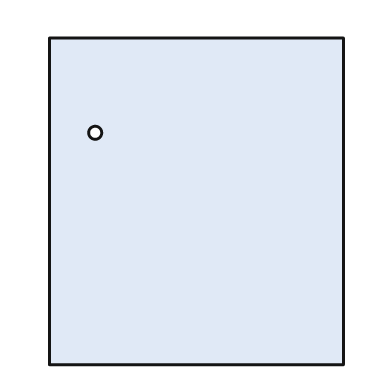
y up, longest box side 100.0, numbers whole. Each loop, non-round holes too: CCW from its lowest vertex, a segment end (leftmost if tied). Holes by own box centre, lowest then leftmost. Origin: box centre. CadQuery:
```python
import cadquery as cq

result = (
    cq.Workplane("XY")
    .moveTo(-45.0, -50.0)
    .lineTo(45.0, -50.0)
    .lineTo(45.0, 50.0)
    .lineTo(-45.0, 50.0)
    .close()
    .moveTo(-31.0, 21.0)
    .circle(2.0)
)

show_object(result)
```